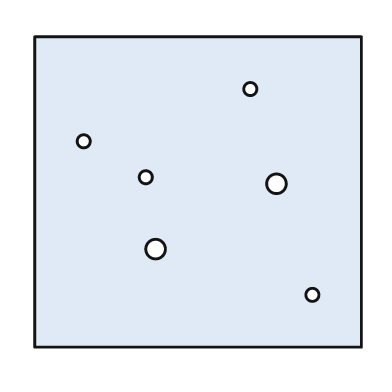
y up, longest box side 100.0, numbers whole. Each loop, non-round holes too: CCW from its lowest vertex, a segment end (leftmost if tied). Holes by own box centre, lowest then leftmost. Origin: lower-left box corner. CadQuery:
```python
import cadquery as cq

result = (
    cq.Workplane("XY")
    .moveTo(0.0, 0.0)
    .lineTo(100.0, 0.0)
    .lineTo(100.0, 95.0)
    .lineTo(0.0, 95.0)
    .close()
    .moveTo(85.0, 16.0)
    .circle(2.0)
    .moveTo(37.0, 30.0)
    .circle(3.0)
    .moveTo(74.0, 50.0)
    .circle(3.0)
    .moveTo(34.0, 52.0)
    .circle(2.0)
    .moveTo(15.0, 63.0)
    .circle(2.0)
    .moveTo(66.0, 79.0)
    .circle(2.0)
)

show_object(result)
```